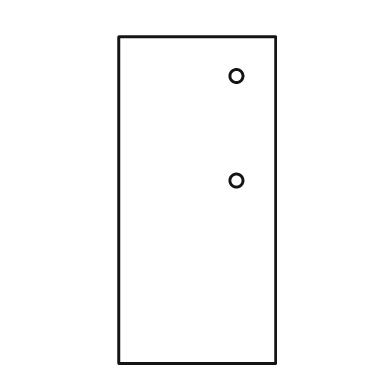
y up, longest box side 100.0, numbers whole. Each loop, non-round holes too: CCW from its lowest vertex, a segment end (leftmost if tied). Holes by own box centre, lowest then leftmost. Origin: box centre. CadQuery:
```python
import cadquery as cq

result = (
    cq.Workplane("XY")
    .moveTo(-24.0, -50.0)
    .lineTo(24.0, -50.0)
    .lineTo(24.0, 50.0)
    .lineTo(-24.0, 50.0)
    .close()
    .moveTo(12.0, 6.0)
    .circle(2.0)
    .moveTo(12.0, 38.0)
    .circle(2.0)
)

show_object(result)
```